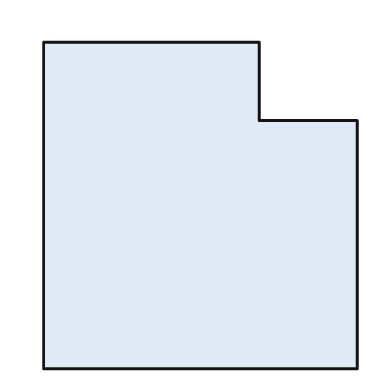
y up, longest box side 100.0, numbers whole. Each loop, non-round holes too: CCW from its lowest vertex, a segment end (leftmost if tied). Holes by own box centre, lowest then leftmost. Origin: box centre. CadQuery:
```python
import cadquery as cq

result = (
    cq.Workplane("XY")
    .moveTo(-48.0, -50.0)
    .lineTo(48.0, -50.0)
    .lineTo(48.0, 26.0)
    .lineTo(18.0, 26.0)
    .lineTo(18.0, 50.0)
    .lineTo(-48.0, 50.0)
    .close()
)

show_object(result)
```